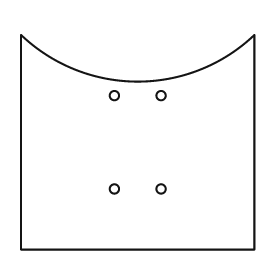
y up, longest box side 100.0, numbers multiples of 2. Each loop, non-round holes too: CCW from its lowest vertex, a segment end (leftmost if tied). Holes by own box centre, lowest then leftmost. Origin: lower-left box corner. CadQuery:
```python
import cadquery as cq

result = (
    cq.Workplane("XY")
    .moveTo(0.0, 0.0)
    .lineTo(100.0, 0.0)
    .lineTo(100.0, 92.0)
    .threePointArc((50.0, 72.0), (0.0, 92.0))
    .close()
    .moveTo(40.0, 26.0)
    .circle(2.0)
    .moveTo(60.0, 26.0)
    .circle(2.0)
    .moveTo(40.0, 66.0)
    .circle(2.0)
    .moveTo(60.0, 66.0)
    .circle(2.0)
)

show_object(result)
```